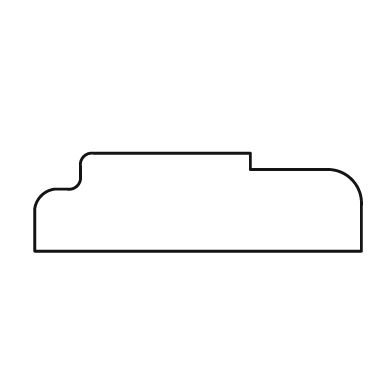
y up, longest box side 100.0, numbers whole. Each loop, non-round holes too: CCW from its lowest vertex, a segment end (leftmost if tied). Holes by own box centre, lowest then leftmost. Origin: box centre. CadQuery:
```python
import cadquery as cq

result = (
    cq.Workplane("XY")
    .moveTo(-50.0, -15.0)
    .lineTo(50.0, -15.0)
    .lineTo(50.0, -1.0)
    .threePointArc((47.0, 7.0), (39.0, 10.0))
    .lineTo(16.0, 10.0)
    .lineTo(16.0, 15.0)
    .lineTo(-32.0, 15.0)
    .threePointArc((-35.0, 14.0), (-36.0, 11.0))
    .lineTo(-36.0, 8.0)
    .threePointArc((-37.0, 5.0), (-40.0, 4.0))
    .lineTo(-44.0, 4.0)
    .threePointArc((-48.0, 2.0), (-50.0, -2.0))
    .close()
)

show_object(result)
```